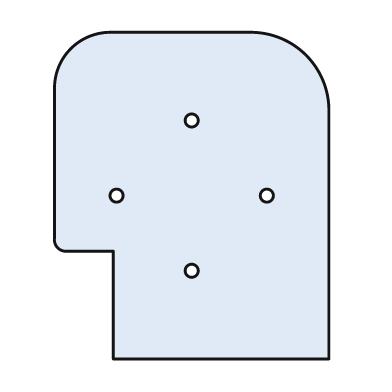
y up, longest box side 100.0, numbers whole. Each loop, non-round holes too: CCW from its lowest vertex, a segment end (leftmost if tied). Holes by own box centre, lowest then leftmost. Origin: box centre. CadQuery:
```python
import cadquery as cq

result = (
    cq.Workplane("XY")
    .moveTo(-24.0, -50.0)
    .lineTo(42.0, -50.0)
    .lineTo(42.0, 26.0)
    .threePointArc((35.0, 43.0), (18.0, 50.0))
    .lineTo(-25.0, 50.0)
    .threePointArc((-37.0, 45.0), (-42.0, 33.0))
    .lineTo(-42.0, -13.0)
    .threePointArc((-41.0, -16.0), (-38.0, -17.0))
    .lineTo(-24.0, -17.0)
    .close()
    .moveTo(0.0, -23.0)
    .circle(2.0)
    .moveTo(-23.0, 0.0)
    .circle(2.0)
    .moveTo(23.0, 0.0)
    .circle(2.0)
    .moveTo(0.0, 23.0)
    .circle(2.0)
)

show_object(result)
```